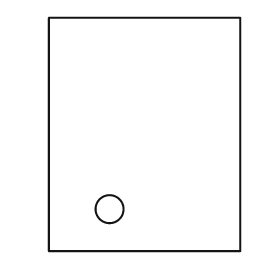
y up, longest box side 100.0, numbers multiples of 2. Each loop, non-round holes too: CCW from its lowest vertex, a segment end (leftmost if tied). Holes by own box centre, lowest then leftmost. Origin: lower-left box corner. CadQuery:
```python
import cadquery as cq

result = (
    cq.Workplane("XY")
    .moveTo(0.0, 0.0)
    .lineTo(82.0, 0.0)
    .lineTo(82.0, 100.0)
    .lineTo(0.0, 100.0)
    .close()
    .moveTo(26.0, 18.0)
    .circle(6.0)
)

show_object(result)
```